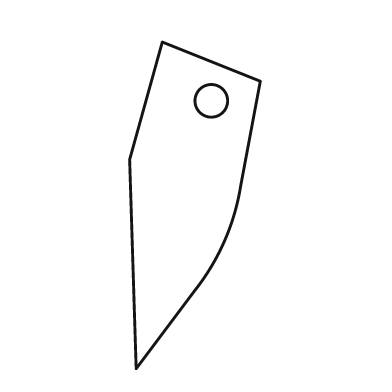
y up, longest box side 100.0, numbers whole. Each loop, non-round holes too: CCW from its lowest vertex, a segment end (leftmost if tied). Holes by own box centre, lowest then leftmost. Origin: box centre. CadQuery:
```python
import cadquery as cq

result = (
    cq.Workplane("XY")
    .moveTo(-18.0, -50.0)
    .lineTo(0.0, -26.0)
    .threePointArc((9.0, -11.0), (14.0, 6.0))
    .lineTo(20.0, 38.0)
    .lineTo(-10.0, 50.0)
    .lineTo(-20.0, 14.0)
    .close()
    .moveTo(5.0, 32.0)
    .circle(5.0)
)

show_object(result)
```